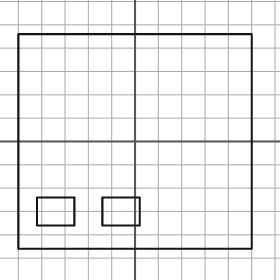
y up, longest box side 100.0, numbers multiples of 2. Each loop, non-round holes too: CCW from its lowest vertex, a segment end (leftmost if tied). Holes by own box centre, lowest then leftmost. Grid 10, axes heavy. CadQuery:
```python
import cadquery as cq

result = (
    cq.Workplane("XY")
    .moveTo(-50.0, -46.0)
    .lineTo(50.0, -46.0)
    .lineTo(50.0, 46.0)
    .lineTo(-50.0, 46.0)
    .close()
    .moveTo(-42.0, -36.0)
    .lineTo(-26.0, -36.0)
    .lineTo(-26.0, -24.0)
    .lineTo(-42.0, -24.0)
    .close()
    .moveTo(-14.0, -36.0)
    .lineTo(2.0, -36.0)
    .lineTo(2.0, -24.0)
    .lineTo(-14.0, -24.0)
    .close()
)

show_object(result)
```